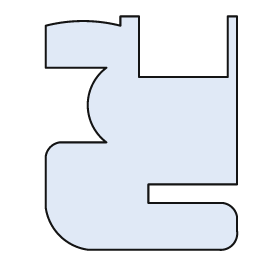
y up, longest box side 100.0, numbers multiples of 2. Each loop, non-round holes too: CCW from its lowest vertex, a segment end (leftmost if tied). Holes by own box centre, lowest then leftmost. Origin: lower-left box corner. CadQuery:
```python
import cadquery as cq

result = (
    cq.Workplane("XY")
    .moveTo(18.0, 0.0)
    .lineTo(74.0, 0.0)
    .threePointArc((80.0, 2.0), (82.0, 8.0))
    .lineTo(82.0, 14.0)
    .threePointArc((80.0, 18.0), (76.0, 20.0))
    .lineTo(44.0, 20.0)
    .lineTo(44.0, 28.0)
    .lineTo(82.0, 28.0)
    .lineTo(82.0, 100.0)
    .lineTo(78.0, 100.0)
    .lineTo(78.0, 74.0)
    .lineTo(40.0, 74.0)
    .lineTo(40.0, 100.0)
    .lineTo(32.0, 100.0)
    .lineTo(32.0, 96.0)
    .threePointArc((16.0, 98.0), (0.0, 96.0))
    .lineTo(0.0, 78.0)
    .lineTo(26.0, 78.0)
    .threePointArc((18.0, 62.0), (26.0, 46.0))
    .lineTo(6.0, 46.0)
    .threePointArc((2.0, 44.0), (0.0, 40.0))
    .lineTo(0.0, 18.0)
    .threePointArc((6.0, 6.0), (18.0, 0.0))
    .close()
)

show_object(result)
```